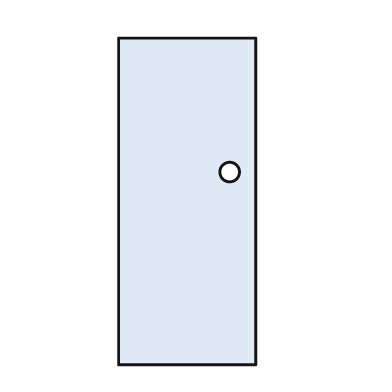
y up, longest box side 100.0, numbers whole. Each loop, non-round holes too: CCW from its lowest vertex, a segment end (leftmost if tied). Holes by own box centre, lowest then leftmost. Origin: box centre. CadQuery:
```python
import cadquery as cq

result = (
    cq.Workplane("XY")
    .moveTo(-21.0, -50.0)
    .lineTo(21.0, -50.0)
    .lineTo(21.0, 50.0)
    .lineTo(-21.0, 50.0)
    .close()
    .moveTo(13.0, 9.0)
    .circle(3.0)
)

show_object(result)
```